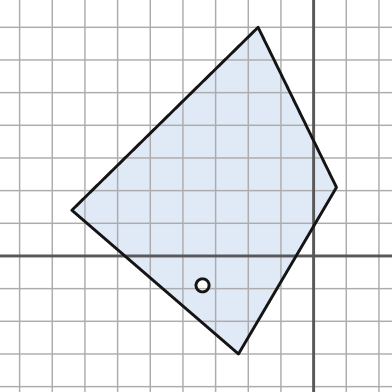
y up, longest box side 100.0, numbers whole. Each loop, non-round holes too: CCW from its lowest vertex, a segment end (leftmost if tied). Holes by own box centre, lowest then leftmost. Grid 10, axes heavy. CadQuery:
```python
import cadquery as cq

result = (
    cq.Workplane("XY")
    .moveTo(-23.0, -30.0)
    .lineTo(7.0, 21.0)
    .lineTo(-17.0, 70.0)
    .lineTo(-74.0, 14.0)
    .close()
    .moveTo(-34.0, -9.0)
    .circle(2.0)
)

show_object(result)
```